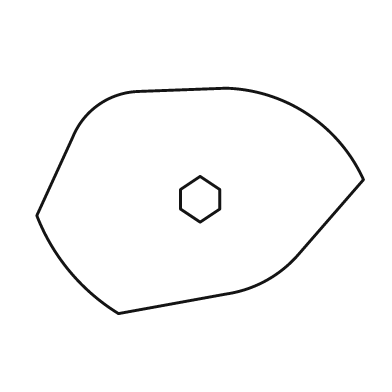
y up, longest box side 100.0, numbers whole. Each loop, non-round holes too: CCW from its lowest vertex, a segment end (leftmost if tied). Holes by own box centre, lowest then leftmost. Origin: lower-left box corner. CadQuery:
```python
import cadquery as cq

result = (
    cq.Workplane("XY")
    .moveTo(25.0, 0.0)
    .lineTo(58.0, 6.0)
    .threePointArc((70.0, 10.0), (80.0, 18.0))
    .lineTo(100.0, 41.0)
    .threePointArc((83.0, 61.0), (58.0, 69.0))
    .lineTo(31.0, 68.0)
    .threePointArc((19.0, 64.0), (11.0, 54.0))
    .lineTo(0.0, 30.0)
    .threePointArc((10.0, 13.0), (25.0, 0.0))
    .close()
    .moveTo(50.0, 28.0)
    .lineTo(56.0, 32.0)
    .lineTo(56.0, 38.0)
    .lineTo(50.0, 42.0)
    .lineTo(44.0, 38.0)
    .lineTo(44.0, 32.0)
    .close()
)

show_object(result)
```